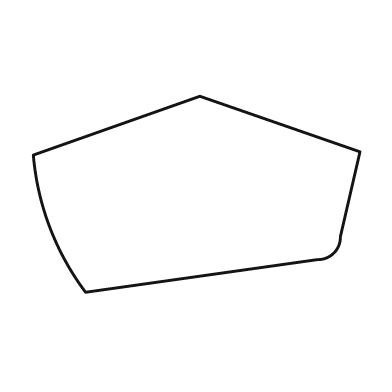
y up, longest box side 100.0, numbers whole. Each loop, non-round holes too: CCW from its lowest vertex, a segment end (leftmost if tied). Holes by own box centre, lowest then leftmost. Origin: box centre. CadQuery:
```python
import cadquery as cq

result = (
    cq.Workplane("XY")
    .moveTo(-34.0, -30.0)
    .lineTo(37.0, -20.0)
    .threePointArc((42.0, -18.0), (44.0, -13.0))
    .lineTo(50.0, 13.0)
    .lineTo(1.0, 30.0)
    .lineTo(-50.0, 12.0)
    .threePointArc((-45.0, -10.0), (-34.0, -30.0))
    .close()
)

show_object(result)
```